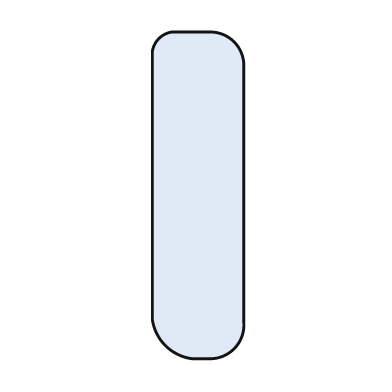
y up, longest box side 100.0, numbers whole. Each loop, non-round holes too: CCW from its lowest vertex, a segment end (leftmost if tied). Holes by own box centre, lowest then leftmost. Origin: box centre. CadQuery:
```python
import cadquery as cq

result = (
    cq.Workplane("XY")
    .moveTo(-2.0, -50.0)
    .lineTo(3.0, -50.0)
    .threePointArc((11.0, -47.0), (14.0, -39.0))
    .lineTo(14.0, 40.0)
    .threePointArc((11.0, 47.0), (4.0, 50.0))
    .lineTo(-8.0, 50.0)
    .threePointArc((-12.0, 48.0), (-14.0, 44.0))
    .lineTo(-14.0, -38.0)
    .threePointArc((-10.0, -46.0), (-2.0, -50.0))
    .close()
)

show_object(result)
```